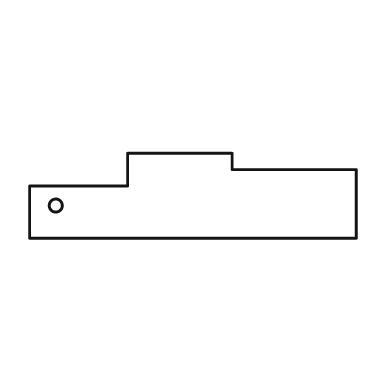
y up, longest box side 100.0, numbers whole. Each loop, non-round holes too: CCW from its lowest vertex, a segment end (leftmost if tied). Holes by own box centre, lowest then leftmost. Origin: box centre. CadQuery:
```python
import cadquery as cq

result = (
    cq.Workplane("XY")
    .moveTo(-50.0, -13.0)
    .lineTo(50.0, -13.0)
    .lineTo(50.0, 8.0)
    .lineTo(12.0, 8.0)
    .lineTo(12.0, 13.0)
    .lineTo(-20.0, 13.0)
    .lineTo(-20.0, 3.0)
    .lineTo(-50.0, 3.0)
    .close()
    .moveTo(-42.0, -3.0)
    .circle(2.0)
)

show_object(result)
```